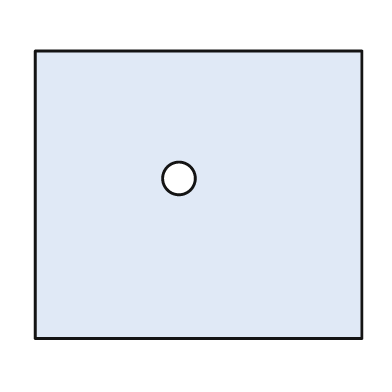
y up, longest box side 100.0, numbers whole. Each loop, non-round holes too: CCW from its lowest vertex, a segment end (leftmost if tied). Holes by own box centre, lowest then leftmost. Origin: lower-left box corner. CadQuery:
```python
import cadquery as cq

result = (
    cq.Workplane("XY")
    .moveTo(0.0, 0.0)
    .lineTo(100.0, 0.0)
    .lineTo(100.0, 88.0)
    .lineTo(0.0, 88.0)
    .close()
    .moveTo(44.0, 49.0)
    .circle(5.0)
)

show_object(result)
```